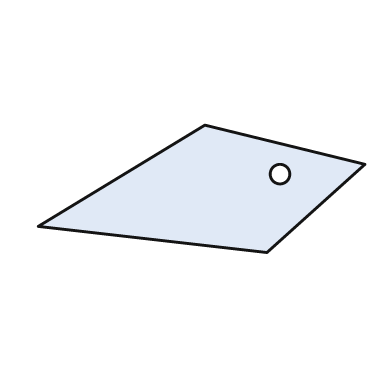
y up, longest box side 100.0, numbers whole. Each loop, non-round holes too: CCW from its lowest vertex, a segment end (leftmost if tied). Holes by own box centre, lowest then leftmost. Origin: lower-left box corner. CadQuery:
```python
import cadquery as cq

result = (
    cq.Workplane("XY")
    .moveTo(70.0, 0.0)
    .lineTo(100.0, 27.0)
    .lineTo(51.0, 39.0)
    .lineTo(0.0, 8.0)
    .close()
    .moveTo(74.0, 24.0)
    .circle(3.0)
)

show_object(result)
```